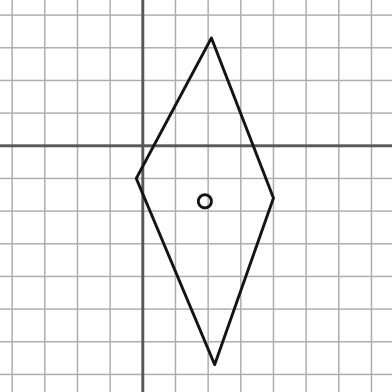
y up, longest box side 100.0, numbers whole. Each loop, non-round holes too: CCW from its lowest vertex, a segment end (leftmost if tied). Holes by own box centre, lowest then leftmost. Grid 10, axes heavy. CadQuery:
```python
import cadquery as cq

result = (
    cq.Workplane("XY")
    .moveTo(22.0, -67.0)
    .lineTo(40.0, -16.0)
    .lineTo(21.0, 33.0)
    .lineTo(-2.0, -10.0)
    .close()
    .moveTo(19.0, -17.0)
    .circle(2.0)
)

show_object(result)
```